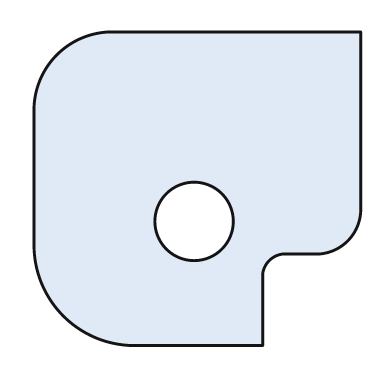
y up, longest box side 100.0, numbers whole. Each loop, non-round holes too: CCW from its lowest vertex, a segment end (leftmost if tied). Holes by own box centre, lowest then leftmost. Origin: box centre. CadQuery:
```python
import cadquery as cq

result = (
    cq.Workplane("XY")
    .moveTo(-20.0, -48.0)
    .lineTo(20.0, -48.0)
    .lineTo(20.0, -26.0)
    .threePointArc((22.0, -22.0), (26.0, -20.0))
    .lineTo(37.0, -20.0)
    .threePointArc((46.0, -16.0), (50.0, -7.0))
    .lineTo(50.0, 48.0)
    .lineTo(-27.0, 48.0)
    .threePointArc((-43.0, 41.0), (-50.0, 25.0))
    .lineTo(-50.0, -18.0)
    .threePointArc((-41.0, -39.0), (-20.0, -48.0))
    .close()
    .moveTo(-1.0, -10.0)
    .circle(12.0)
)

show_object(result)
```